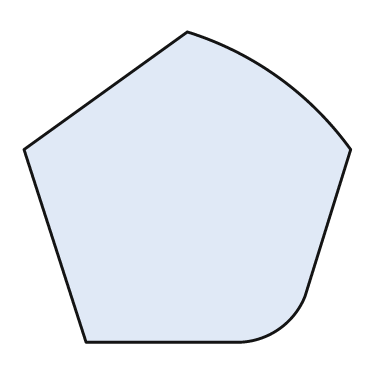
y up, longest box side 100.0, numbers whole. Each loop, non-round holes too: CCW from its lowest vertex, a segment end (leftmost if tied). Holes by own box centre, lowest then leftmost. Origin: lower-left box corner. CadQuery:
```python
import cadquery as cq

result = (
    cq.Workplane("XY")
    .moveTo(19.0, 0.0)
    .lineTo(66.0, 0.0)
    .threePointArc((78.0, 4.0), (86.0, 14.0))
    .lineTo(100.0, 59.0)
    .threePointArc((78.0, 81.0), (50.0, 95.0))
    .lineTo(0.0, 59.0)
    .close()
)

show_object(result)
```